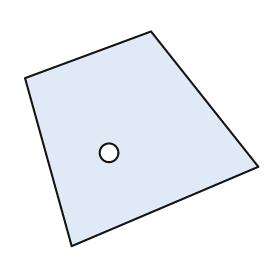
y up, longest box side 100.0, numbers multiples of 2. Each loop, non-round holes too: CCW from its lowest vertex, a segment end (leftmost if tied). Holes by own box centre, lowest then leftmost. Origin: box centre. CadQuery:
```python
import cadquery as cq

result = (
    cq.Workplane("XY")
    .moveTo(-30.0, -46.0)
    .lineTo(50.0, -12.0)
    .lineTo(4.0, 46.0)
    .lineTo(-50.0, 26.0)
    .close()
    .moveTo(-14.0, -6.0)
    .circle(4.0)
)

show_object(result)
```